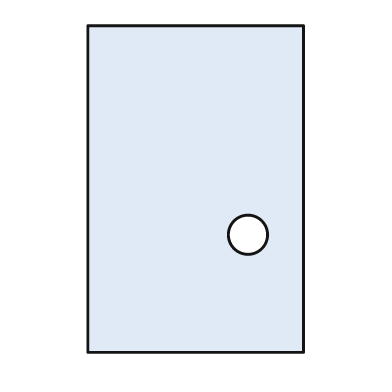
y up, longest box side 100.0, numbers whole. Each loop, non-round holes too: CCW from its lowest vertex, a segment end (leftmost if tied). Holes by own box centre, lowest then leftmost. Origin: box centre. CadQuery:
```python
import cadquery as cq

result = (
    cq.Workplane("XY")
    .moveTo(-33.0, -50.0)
    .lineTo(33.0, -50.0)
    .lineTo(33.0, 50.0)
    .lineTo(-33.0, 50.0)
    .close()
    .moveTo(16.0, -14.0)
    .circle(6.0)
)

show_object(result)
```